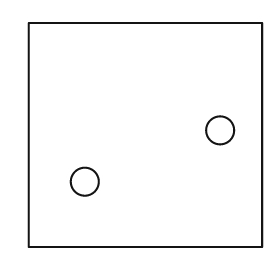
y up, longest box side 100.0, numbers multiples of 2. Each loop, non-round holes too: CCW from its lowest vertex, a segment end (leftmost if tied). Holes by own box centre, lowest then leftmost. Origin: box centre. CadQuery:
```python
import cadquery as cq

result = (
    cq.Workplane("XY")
    .moveTo(-50.0, -48.0)
    .lineTo(50.0, -48.0)
    .lineTo(50.0, 48.0)
    .lineTo(-50.0, 48.0)
    .close()
    .moveTo(-26.0, -20.0)
    .circle(6.0)
    .moveTo(32.0, 2.0)
    .circle(6.0)
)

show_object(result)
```